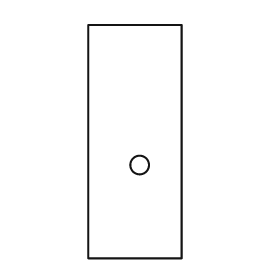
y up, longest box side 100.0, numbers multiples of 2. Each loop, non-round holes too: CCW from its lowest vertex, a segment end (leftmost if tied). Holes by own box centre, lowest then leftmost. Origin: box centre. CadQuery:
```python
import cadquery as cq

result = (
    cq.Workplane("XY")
    .moveTo(-20.0, -50.0)
    .lineTo(20.0, -50.0)
    .lineTo(20.0, 50.0)
    .lineTo(-20.0, 50.0)
    .close()
    .moveTo(2.0, -10.0)
    .circle(4.0)
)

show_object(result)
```